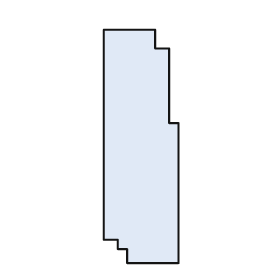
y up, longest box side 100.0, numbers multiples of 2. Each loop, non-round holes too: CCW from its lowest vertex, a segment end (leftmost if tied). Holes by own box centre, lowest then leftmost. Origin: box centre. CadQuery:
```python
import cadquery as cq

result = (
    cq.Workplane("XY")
    .moveTo(-6.0, -50.0)
    .lineTo(16.0, -50.0)
    .lineTo(16.0, 10.0)
    .lineTo(12.0, 10.0)
    .lineTo(12.0, 42.0)
    .lineTo(6.0, 42.0)
    .lineTo(6.0, 50.0)
    .lineTo(-16.0, 50.0)
    .lineTo(-16.0, -40.0)
    .lineTo(-10.0, -40.0)
    .lineTo(-10.0, -44.0)
    .lineTo(-6.0, -44.0)
    .close()
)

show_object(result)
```